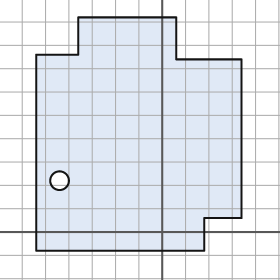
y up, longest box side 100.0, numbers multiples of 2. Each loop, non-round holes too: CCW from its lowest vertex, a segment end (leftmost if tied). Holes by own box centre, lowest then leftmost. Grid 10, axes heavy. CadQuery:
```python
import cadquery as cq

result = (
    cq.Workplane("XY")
    .moveTo(-54.0, -8.0)
    .lineTo(18.0, -8.0)
    .lineTo(18.0, 6.0)
    .lineTo(34.0, 6.0)
    .lineTo(34.0, 74.0)
    .lineTo(6.0, 74.0)
    .lineTo(6.0, 92.0)
    .lineTo(-36.0, 92.0)
    .lineTo(-36.0, 76.0)
    .lineTo(-54.0, 76.0)
    .close()
    .moveTo(-44.0, 22.0)
    .circle(4.0)
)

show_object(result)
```